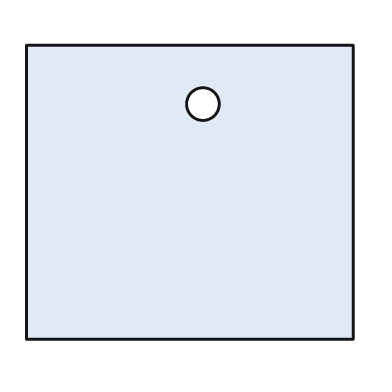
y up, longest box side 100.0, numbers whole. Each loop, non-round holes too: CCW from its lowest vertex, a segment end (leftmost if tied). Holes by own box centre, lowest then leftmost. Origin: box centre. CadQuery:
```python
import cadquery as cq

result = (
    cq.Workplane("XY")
    .moveTo(-50.0, -45.0)
    .lineTo(50.0, -45.0)
    .lineTo(50.0, 45.0)
    .lineTo(-50.0, 45.0)
    .close()
    .moveTo(4.0, 27.0)
    .circle(5.0)
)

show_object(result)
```